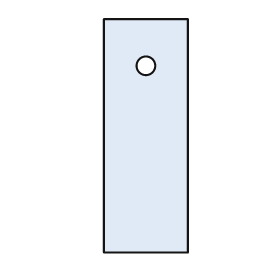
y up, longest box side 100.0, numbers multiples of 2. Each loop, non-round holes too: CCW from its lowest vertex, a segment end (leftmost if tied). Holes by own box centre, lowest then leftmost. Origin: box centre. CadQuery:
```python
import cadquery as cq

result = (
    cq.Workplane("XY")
    .moveTo(-18.0, -50.0)
    .lineTo(18.0, -50.0)
    .lineTo(18.0, 50.0)
    .lineTo(-18.0, 50.0)
    .close()
    .moveTo(0.0, 30.0)
    .circle(4.0)
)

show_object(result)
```